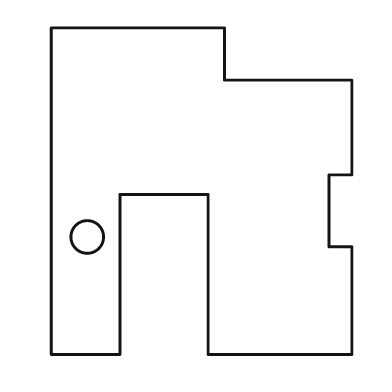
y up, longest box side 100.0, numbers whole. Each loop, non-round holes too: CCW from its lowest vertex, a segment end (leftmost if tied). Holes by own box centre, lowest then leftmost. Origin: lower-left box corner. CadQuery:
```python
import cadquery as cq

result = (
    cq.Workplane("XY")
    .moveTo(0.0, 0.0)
    .lineTo(21.0, 0.0)
    .lineTo(21.0, 49.0)
    .lineTo(48.0, 49.0)
    .lineTo(48.0, 0.0)
    .lineTo(92.0, 0.0)
    .lineTo(92.0, 33.0)
    .lineTo(85.0, 33.0)
    .lineTo(85.0, 55.0)
    .lineTo(92.0, 55.0)
    .lineTo(92.0, 84.0)
    .lineTo(53.0, 84.0)
    .lineTo(53.0, 100.0)
    .lineTo(0.0, 100.0)
    .close()
    .moveTo(11.0, 36.0)
    .circle(5.0)
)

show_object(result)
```